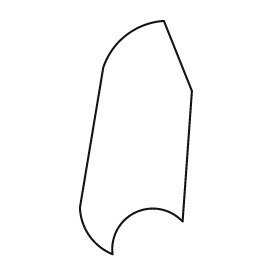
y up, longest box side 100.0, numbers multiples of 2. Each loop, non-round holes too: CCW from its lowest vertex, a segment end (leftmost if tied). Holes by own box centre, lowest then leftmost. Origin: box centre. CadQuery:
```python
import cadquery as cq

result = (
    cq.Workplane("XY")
    .moveTo(-10.0, -50.0)
    .threePointArc((0.0, -32.0), (20.0, -36.0))
    .lineTo(24.0, 20.0)
    .lineTo(12.0, 50.0)
    .threePointArc((-4.0, 44.0), (-14.0, 30.0))
    .lineTo(-24.0, -30.0)
    .threePointArc((-20.0, -42.0), (-10.0, -50.0))
    .close()
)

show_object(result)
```